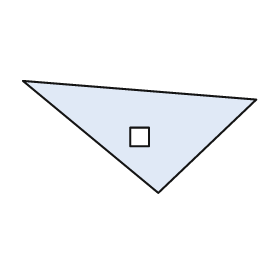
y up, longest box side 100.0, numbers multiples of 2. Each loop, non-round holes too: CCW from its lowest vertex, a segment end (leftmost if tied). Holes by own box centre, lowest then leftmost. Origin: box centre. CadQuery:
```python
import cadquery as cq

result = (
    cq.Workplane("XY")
    .moveTo(8.0, -24.0)
    .lineTo(50.0, 16.0)
    .lineTo(-50.0, 24.0)
    .close()
    .moveTo(-4.0, -4.0)
    .lineTo(4.0, -4.0)
    .lineTo(4.0, 4.0)
    .lineTo(-4.0, 4.0)
    .close()
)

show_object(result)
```